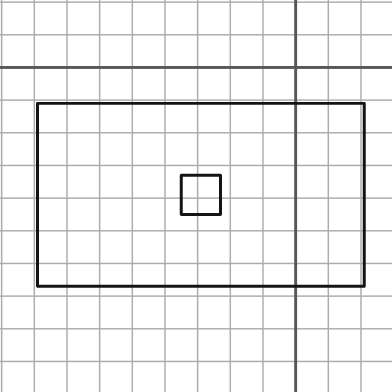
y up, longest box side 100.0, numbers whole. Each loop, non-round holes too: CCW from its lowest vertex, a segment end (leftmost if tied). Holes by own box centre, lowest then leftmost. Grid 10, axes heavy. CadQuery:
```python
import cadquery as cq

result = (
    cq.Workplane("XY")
    .moveTo(-79.0, -67.0)
    .lineTo(21.0, -67.0)
    .lineTo(21.0, -11.0)
    .lineTo(-79.0, -11.0)
    .close()
    .moveTo(-35.0, -45.0)
    .lineTo(-23.0, -45.0)
    .lineTo(-23.0, -33.0)
    .lineTo(-35.0, -33.0)
    .close()
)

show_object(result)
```